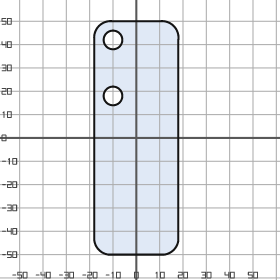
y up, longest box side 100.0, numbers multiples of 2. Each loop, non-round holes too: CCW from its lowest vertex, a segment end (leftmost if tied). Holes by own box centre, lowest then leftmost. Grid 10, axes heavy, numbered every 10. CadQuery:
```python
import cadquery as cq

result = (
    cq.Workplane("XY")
    .moveTo(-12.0, -50.0)
    .lineTo(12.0, -50.0)
    .threePointArc((16.0, -48.0), (18.0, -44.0))
    .lineTo(18.0, 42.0)
    .threePointArc((16.0, 48.0), (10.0, 50.0))
    .lineTo(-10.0, 50.0)
    .threePointArc((-16.0, 48.0), (-18.0, 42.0))
    .lineTo(-18.0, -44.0)
    .threePointArc((-16.0, -48.0), (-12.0, -50.0))
    .close()
    .moveTo(-10.0, 18.0)
    .circle(4.0)
    .moveTo(-10.0, 42.0)
    .circle(4.0)
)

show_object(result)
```